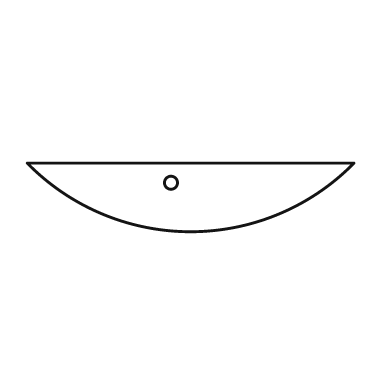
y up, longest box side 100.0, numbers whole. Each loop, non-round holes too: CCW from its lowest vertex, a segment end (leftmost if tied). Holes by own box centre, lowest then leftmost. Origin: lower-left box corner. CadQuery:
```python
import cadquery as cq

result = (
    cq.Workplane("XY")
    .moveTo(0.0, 21.0)
    .threePointArc((50.0, 0.0), (100.0, 21.0))
    .close()
    .moveTo(44.0, 15.0)
    .circle(2.0)
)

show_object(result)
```